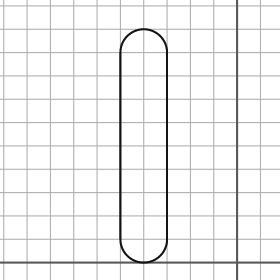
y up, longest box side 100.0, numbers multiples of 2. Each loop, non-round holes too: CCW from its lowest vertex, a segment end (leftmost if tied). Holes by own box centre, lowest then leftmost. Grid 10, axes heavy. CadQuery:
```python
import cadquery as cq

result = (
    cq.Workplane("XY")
    .moveTo(-50.0, 10.0)
    .threePointArc((-40.0, 0.0), (-30.0, 10.0))
    .lineTo(-30.0, 90.0)
    .threePointArc((-40.0, 100.0), (-50.0, 90.0))
    .close()
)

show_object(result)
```